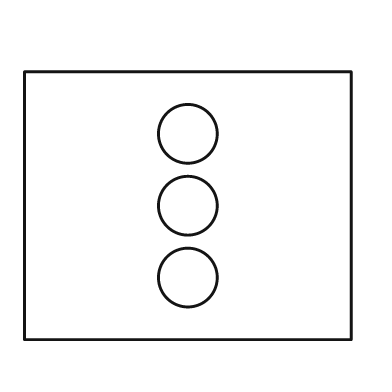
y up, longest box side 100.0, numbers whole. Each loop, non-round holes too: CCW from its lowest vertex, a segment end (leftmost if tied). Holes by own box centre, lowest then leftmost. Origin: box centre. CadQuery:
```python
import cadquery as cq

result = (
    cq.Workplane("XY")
    .moveTo(-50.0, -41.0)
    .lineTo(50.0, -41.0)
    .lineTo(50.0, 41.0)
    .lineTo(-50.0, 41.0)
    .close()
    .moveTo(0.0, -22.0)
    .circle(9.0)
    .moveTo(0.0, 0.0)
    .circle(9.0)
    .moveTo(0.0, 22.0)
    .circle(9.0)
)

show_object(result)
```